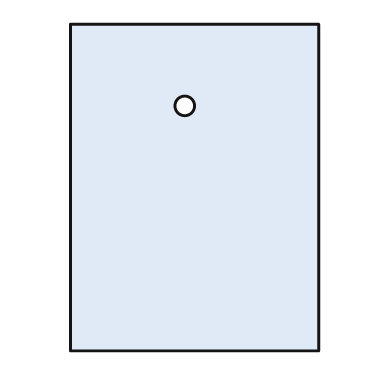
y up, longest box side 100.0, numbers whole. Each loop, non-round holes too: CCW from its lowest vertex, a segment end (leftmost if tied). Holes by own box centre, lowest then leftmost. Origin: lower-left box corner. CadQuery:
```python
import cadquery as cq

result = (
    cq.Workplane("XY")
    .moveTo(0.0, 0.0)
    .lineTo(76.0, 0.0)
    .lineTo(76.0, 100.0)
    .lineTo(0.0, 100.0)
    .close()
    .moveTo(35.0, 75.0)
    .circle(3.0)
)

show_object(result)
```